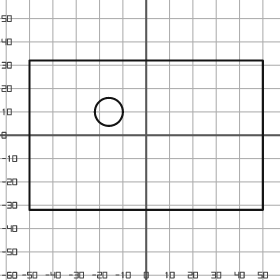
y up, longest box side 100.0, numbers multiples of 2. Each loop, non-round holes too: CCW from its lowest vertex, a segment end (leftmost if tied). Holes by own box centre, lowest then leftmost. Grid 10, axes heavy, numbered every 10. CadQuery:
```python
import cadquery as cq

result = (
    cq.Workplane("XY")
    .moveTo(-50.0, -32.0)
    .lineTo(50.0, -32.0)
    .lineTo(50.0, 32.0)
    .lineTo(-50.0, 32.0)
    .close()
    .moveTo(-16.0, 10.0)
    .circle(6.0)
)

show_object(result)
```